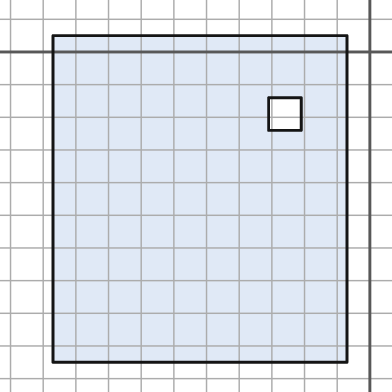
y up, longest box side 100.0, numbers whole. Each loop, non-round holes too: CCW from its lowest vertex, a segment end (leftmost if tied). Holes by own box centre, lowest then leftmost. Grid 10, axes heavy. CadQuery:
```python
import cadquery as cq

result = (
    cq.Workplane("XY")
    .moveTo(-97.0, -95.0)
    .lineTo(-7.0, -95.0)
    .lineTo(-7.0, 5.0)
    .lineTo(-97.0, 5.0)
    .close()
    .moveTo(-31.0, -24.0)
    .lineTo(-21.0, -24.0)
    .lineTo(-21.0, -14.0)
    .lineTo(-31.0, -14.0)
    .close()
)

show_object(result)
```